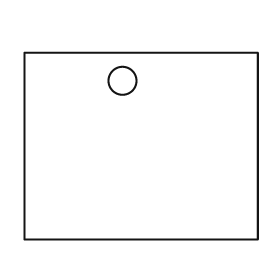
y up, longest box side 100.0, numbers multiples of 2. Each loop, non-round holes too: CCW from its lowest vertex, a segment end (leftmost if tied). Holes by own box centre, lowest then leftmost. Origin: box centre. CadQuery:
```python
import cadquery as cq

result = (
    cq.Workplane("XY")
    .moveTo(-50.0, -40.0)
    .lineTo(50.0, -40.0)
    .lineTo(50.0, 40.0)
    .lineTo(-50.0, 40.0)
    .close()
    .moveTo(-8.0, 28.0)
    .circle(6.0)
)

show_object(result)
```